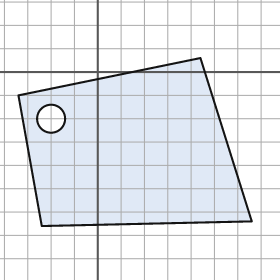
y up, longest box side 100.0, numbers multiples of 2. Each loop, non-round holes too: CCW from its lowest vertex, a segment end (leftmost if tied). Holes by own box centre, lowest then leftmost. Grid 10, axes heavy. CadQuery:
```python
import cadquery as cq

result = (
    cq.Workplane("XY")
    .moveTo(-24.0, -66.0)
    .lineTo(66.0, -64.0)
    .lineTo(44.0, 6.0)
    .lineTo(-34.0, -10.0)
    .close()
    .moveTo(-20.0, -20.0)
    .circle(6.0)
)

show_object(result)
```